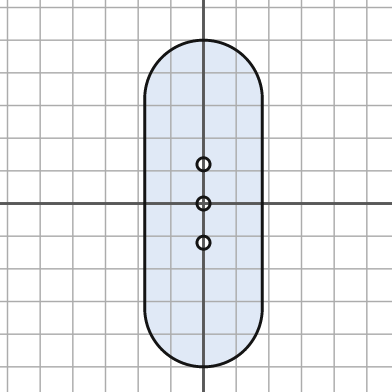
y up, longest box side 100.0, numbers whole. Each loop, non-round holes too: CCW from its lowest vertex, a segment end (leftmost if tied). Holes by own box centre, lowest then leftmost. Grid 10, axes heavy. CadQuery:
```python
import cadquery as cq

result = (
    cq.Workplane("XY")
    .moveTo(-18.0, -32.0)
    .threePointArc((0.0, -50.0), (18.0, -32.0))
    .lineTo(18.0, 32.0)
    .threePointArc((0.0, 50.0), (-18.0, 32.0))
    .close()
    .moveTo(0.0, -12.0)
    .circle(2.0)
    .moveTo(0.0, 0.0)
    .circle(2.0)
    .moveTo(0.0, 12.0)
    .circle(2.0)
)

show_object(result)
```